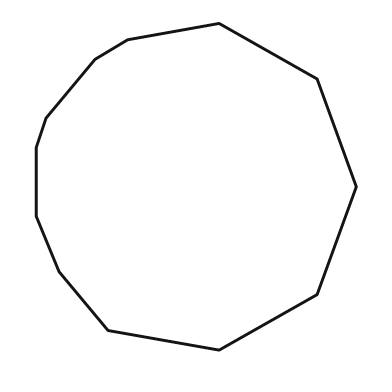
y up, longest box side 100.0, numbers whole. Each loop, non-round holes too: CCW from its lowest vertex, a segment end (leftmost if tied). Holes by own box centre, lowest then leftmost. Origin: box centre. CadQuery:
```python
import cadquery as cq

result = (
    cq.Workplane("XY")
    .moveTo(7.0, -50.0)
    .lineTo(37.0, -33.0)
    .lineTo(49.0, 0.0)
    .lineTo(37.0, 33.0)
    .lineTo(7.0, 50.0)
    .lineTo(-21.0, 45.0)
    .lineTo(-31.0, 39.0)
    .lineTo(-46.0, 21.0)
    .lineTo(-49.0, 12.0)
    .lineTo(-49.0, -9.0)
    .lineTo(-42.0, -26.0)
    .lineTo(-27.0, -44.0)
    .close()
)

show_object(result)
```